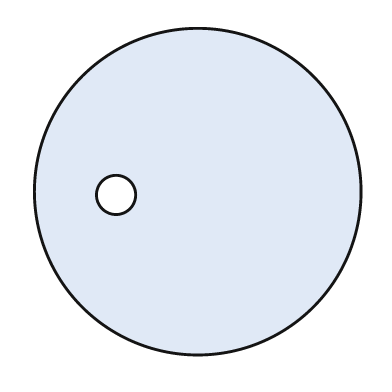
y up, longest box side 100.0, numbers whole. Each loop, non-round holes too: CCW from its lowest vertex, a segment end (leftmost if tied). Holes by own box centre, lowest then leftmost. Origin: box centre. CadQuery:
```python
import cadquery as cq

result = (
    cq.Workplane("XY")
    .moveTo(0.0, 0.0)
    .circle(50.0)
    .moveTo(-25.0, -1.0)
    .circle(6.0)
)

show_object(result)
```